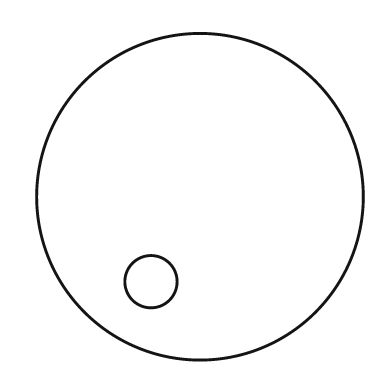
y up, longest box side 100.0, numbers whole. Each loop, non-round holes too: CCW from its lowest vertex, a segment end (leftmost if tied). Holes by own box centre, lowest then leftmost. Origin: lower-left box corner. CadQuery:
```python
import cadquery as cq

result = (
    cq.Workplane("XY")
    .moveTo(50.0, 50.0)
    .circle(50.0)
    .moveTo(35.0, 24.0)
    .circle(8.0)
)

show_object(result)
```